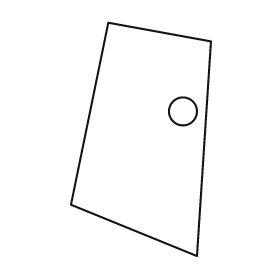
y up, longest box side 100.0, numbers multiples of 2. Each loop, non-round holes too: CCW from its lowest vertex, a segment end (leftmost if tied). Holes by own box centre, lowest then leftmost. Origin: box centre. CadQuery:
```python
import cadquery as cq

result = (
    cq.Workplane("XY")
    .moveTo(24.0, -50.0)
    .lineTo(30.0, 42.0)
    .lineTo(-14.0, 50.0)
    .lineTo(-30.0, -28.0)
    .close()
    .moveTo(18.0, 12.0)
    .circle(6.0)
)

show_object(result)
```